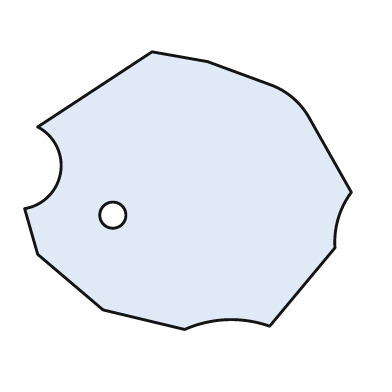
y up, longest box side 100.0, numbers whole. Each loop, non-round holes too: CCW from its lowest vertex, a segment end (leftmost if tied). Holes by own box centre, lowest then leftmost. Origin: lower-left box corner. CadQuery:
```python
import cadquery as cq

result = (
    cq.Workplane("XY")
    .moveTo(49.0, 0.0)
    .threePointArc((62.0, 3.0), (75.0, 1.0))
    .lineTo(95.0, 25.0)
    .threePointArc((96.0, 34.0), (100.0, 42.0))
    .lineTo(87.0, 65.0)
    .threePointArc((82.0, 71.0), (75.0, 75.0))
    .lineTo(56.0, 82.0)
    .lineTo(39.0, 85.0)
    .lineTo(4.0, 62.0)
    .threePointArc((11.0, 48.0), (0.0, 37.0))
    .lineTo(4.0, 23.0)
    .lineTo(24.0, 6.0)
    .close()
    .moveTo(27.0, 35.0)
    .circle(4.0)
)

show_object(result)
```